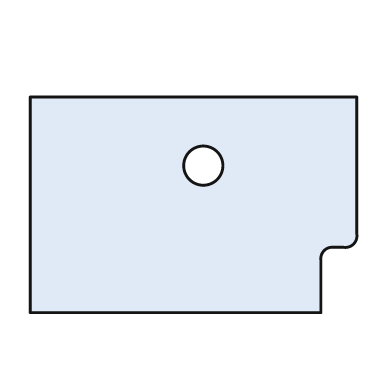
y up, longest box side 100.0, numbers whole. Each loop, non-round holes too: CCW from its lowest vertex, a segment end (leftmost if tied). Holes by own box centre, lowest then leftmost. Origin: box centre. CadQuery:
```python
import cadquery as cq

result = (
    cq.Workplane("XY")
    .moveTo(-50.0, -33.0)
    .lineTo(39.0, -33.0)
    .lineTo(39.0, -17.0)
    .threePointArc((40.0, -14.0), (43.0, -13.0))
    .lineTo(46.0, -13.0)
    .threePointArc((49.0, -12.0), (50.0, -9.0))
    .lineTo(50.0, 33.0)
    .lineTo(-50.0, 33.0)
    .close()
    .moveTo(3.0, 12.0)
    .circle(6.0)
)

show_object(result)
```